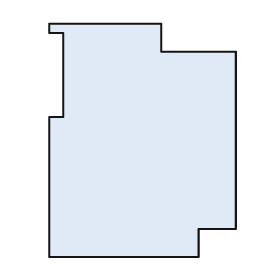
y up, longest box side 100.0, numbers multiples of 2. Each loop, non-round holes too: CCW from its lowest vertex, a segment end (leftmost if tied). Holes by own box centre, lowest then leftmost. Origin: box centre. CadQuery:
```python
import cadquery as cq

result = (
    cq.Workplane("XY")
    .moveTo(-40.0, -50.0)
    .lineTo(24.0, -50.0)
    .lineTo(24.0, -38.0)
    .lineTo(40.0, -38.0)
    .lineTo(40.0, 38.0)
    .lineTo(8.0, 38.0)
    .lineTo(8.0, 50.0)
    .lineTo(-40.0, 50.0)
    .lineTo(-40.0, 46.0)
    .lineTo(-34.0, 46.0)
    .lineTo(-34.0, 10.0)
    .lineTo(-40.0, 10.0)
    .close()
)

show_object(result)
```